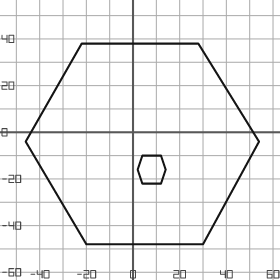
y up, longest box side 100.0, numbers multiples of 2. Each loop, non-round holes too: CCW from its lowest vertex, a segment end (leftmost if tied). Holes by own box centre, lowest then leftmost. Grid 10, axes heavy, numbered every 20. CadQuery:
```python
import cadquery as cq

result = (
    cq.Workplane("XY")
    .moveTo(-20.0, -48.0)
    .lineTo(30.0, -48.0)
    .lineTo(54.0, -4.0)
    .lineTo(28.0, 38.0)
    .lineTo(-22.0, 38.0)
    .lineTo(-46.0, -4.0)
    .close()
    .moveTo(4.0, -22.0)
    .lineTo(12.0, -22.0)
    .lineTo(14.0, -16.0)
    .lineTo(12.0, -10.0)
    .lineTo(4.0, -10.0)
    .lineTo(2.0, -16.0)
    .close()
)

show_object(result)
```